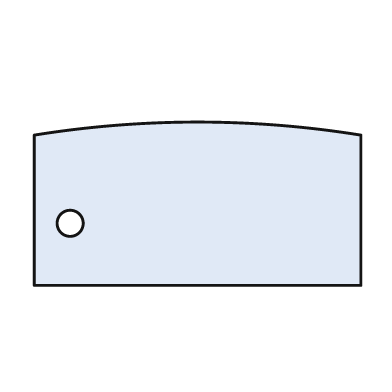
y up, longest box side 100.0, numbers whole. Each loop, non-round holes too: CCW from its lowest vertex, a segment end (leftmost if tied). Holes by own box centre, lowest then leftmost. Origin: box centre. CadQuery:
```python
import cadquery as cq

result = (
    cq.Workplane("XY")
    .moveTo(-50.0, -25.0)
    .lineTo(50.0, -25.0)
    .lineTo(50.0, 21.0)
    .threePointArc((0.0, 25.0), (-50.0, 21.0))
    .close()
    .moveTo(-39.0, -6.0)
    .circle(4.0)
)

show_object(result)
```